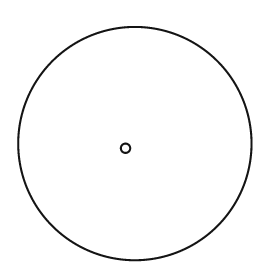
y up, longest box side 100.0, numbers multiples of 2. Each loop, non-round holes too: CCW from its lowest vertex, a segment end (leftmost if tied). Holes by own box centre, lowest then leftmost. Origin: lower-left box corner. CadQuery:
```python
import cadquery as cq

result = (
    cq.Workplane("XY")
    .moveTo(50.0, 50.0)
    .circle(50.0)
    .moveTo(46.0, 48.0)
    .circle(2.0)
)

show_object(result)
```